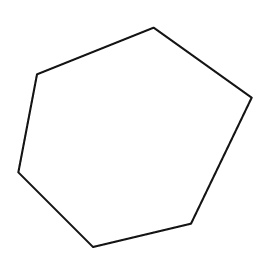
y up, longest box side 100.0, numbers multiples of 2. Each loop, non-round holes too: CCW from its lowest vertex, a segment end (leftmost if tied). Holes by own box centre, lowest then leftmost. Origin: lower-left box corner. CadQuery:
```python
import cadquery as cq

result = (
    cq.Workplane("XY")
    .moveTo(32.0, 0.0)
    .lineTo(74.0, 10.0)
    .lineTo(100.0, 64.0)
    .lineTo(58.0, 94.0)
    .lineTo(8.0, 74.0)
    .lineTo(0.0, 32.0)
    .close()
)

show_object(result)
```